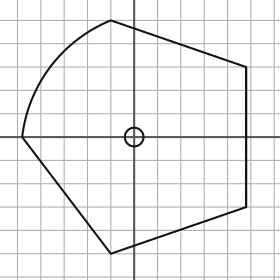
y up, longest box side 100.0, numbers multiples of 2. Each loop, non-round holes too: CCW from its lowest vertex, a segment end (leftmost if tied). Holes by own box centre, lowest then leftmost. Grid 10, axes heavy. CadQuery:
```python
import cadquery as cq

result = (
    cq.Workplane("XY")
    .moveTo(-10.0, -50.0)
    .lineTo(48.0, -30.0)
    .lineTo(48.0, 30.0)
    .lineTo(-10.0, 50.0)
    .threePointArc((-36.0, 30.0), (-48.0, 0.0))
    .close()
    .moveTo(0.0, 0.0)
    .circle(4.0)
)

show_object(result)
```